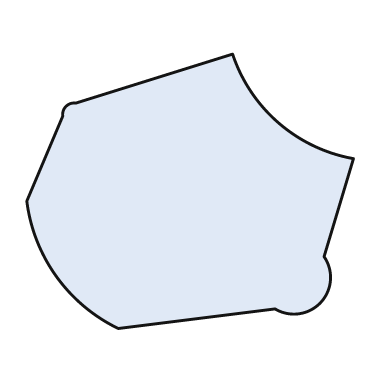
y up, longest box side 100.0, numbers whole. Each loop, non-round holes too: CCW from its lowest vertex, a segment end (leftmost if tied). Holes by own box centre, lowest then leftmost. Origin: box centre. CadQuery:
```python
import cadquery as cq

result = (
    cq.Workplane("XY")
    .moveTo(-22.0, -42.0)
    .lineTo(26.0, -36.0)
    .threePointArc((40.0, -34.0), (41.0, -20.0))
    .lineTo(50.0, 10.0)
    .threePointArc((27.0, 21.0), (13.0, 42.0))
    .lineTo(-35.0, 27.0)
    .threePointArc((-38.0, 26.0), (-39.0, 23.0))
    .lineTo(-50.0, -3.0)
    .threePointArc((-41.0, -26.0), (-22.0, -42.0))
    .close()
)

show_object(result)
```